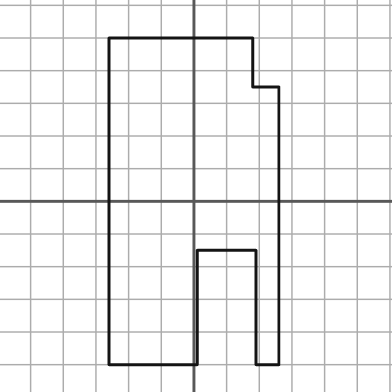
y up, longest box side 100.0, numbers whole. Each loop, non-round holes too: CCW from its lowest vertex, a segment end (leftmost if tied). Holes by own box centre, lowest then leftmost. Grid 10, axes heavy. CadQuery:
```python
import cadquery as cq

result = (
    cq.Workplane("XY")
    .moveTo(-26.0, -50.0)
    .lineTo(1.0, -50.0)
    .lineTo(1.0, -15.0)
    .lineTo(19.0, -15.0)
    .lineTo(19.0, -50.0)
    .lineTo(26.0, -50.0)
    .lineTo(26.0, 35.0)
    .lineTo(18.0, 35.0)
    .lineTo(18.0, 50.0)
    .lineTo(-26.0, 50.0)
    .close()
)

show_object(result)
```